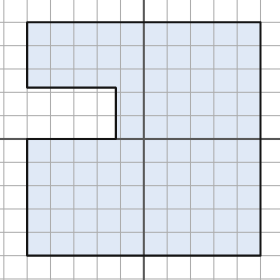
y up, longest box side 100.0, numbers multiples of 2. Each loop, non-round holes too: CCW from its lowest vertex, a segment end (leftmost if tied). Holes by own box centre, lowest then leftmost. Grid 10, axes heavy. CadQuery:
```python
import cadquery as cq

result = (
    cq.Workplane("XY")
    .moveTo(-50.0, -50.0)
    .lineTo(50.0, -50.0)
    .lineTo(50.0, 50.0)
    .lineTo(-50.0, 50.0)
    .lineTo(-50.0, 22.0)
    .lineTo(-12.0, 22.0)
    .lineTo(-12.0, 0.0)
    .lineTo(-50.0, 0.0)
    .close()
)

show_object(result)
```